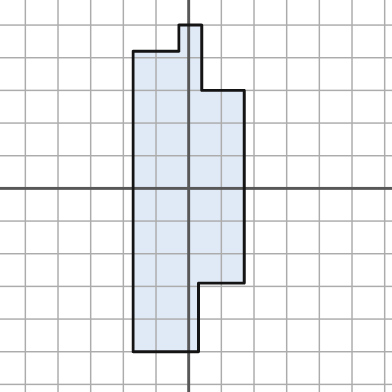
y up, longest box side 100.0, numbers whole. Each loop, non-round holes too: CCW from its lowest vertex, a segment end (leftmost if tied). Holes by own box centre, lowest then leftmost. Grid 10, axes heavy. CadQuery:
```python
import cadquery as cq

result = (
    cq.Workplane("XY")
    .moveTo(-17.0, -50.0)
    .lineTo(3.0, -50.0)
    .lineTo(3.0, -29.0)
    .lineTo(17.0, -29.0)
    .lineTo(17.0, 30.0)
    .lineTo(4.0, 30.0)
    .lineTo(4.0, 50.0)
    .lineTo(-3.0, 50.0)
    .lineTo(-3.0, 42.0)
    .lineTo(-17.0, 42.0)
    .close()
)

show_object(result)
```